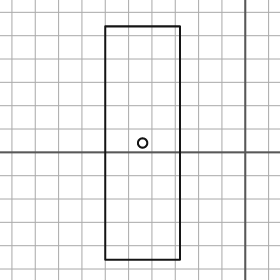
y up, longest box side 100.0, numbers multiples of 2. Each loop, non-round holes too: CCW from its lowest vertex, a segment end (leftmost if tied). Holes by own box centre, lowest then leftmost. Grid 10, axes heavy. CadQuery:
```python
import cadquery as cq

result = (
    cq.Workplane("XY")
    .moveTo(-60.0, -46.0)
    .lineTo(-28.0, -46.0)
    .lineTo(-28.0, 54.0)
    .lineTo(-60.0, 54.0)
    .close()
    .moveTo(-44.0, 4.0)
    .circle(2.0)
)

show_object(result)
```